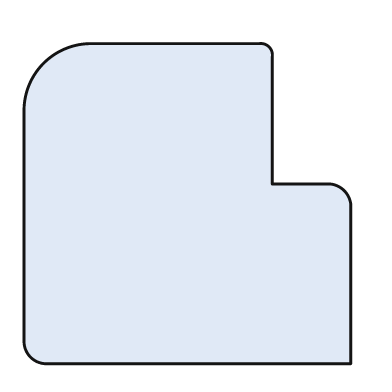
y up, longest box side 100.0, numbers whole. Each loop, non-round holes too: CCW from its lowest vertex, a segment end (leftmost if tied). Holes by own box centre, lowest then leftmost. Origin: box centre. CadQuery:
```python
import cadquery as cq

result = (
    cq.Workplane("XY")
    .moveTo(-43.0, -49.0)
    .lineTo(50.0, -49.0)
    .lineTo(50.0, 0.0)
    .threePointArc((48.0, 4.0), (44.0, 6.0))
    .lineTo(26.0, 6.0)
    .lineTo(26.0, 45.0)
    .threePointArc((25.0, 48.0), (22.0, 49.0))
    .lineTo(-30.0, 49.0)
    .threePointArc((-44.0, 43.0), (-50.0, 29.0))
    .lineTo(-50.0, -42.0)
    .threePointArc((-48.0, -47.0), (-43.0, -49.0))
    .close()
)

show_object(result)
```